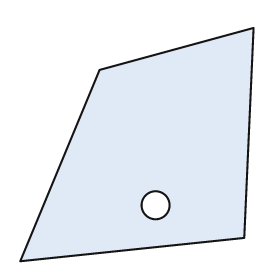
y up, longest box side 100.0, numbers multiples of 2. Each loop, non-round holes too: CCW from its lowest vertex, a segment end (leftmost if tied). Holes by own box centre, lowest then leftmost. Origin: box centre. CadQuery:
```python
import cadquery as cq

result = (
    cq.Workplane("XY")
    .moveTo(-50.0, -50.0)
    .lineTo(46.0, -40.0)
    .lineTo(50.0, 50.0)
    .lineTo(-16.0, 32.0)
    .close()
    .moveTo(8.0, -26.0)
    .circle(6.0)
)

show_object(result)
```